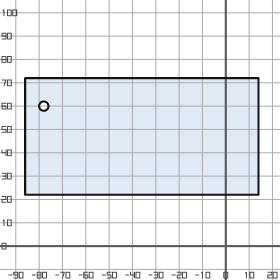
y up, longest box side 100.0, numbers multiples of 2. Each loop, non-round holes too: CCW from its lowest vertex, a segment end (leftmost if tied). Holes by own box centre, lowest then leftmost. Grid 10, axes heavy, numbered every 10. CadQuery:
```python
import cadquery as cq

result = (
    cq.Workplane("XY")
    .moveTo(-86.0, 22.0)
    .lineTo(14.0, 22.0)
    .lineTo(14.0, 72.0)
    .lineTo(-86.0, 72.0)
    .close()
    .moveTo(-78.0, 60.0)
    .circle(2.0)
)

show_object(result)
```